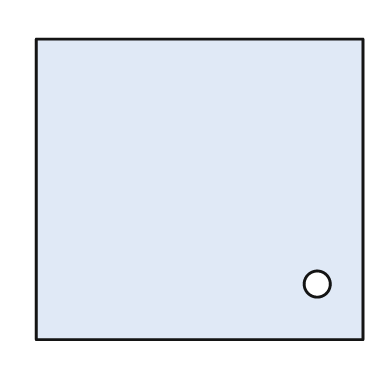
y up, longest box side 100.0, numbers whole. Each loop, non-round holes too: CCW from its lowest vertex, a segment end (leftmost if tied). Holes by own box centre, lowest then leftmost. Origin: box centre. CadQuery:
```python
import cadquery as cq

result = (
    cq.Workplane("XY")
    .moveTo(-50.0, -46.0)
    .lineTo(50.0, -46.0)
    .lineTo(50.0, 46.0)
    .lineTo(-50.0, 46.0)
    .close()
    .moveTo(36.0, -29.0)
    .circle(4.0)
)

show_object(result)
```